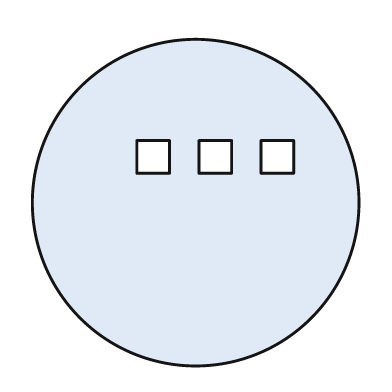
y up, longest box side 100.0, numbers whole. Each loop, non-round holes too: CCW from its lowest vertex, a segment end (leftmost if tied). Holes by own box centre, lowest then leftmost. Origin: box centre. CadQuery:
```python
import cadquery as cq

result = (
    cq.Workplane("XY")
    .moveTo(0.0, 0.0)
    .circle(50.0)
    .moveTo(-18.0, 9.0)
    .lineTo(-8.0, 9.0)
    .lineTo(-8.0, 19.0)
    .lineTo(-18.0, 19.0)
    .close()
    .moveTo(1.0, 9.0)
    .lineTo(11.0, 9.0)
    .lineTo(11.0, 19.0)
    .lineTo(1.0, 19.0)
    .close()
    .moveTo(20.0, 9.0)
    .lineTo(30.0, 9.0)
    .lineTo(30.0, 19.0)
    .lineTo(20.0, 19.0)
    .close()
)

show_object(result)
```